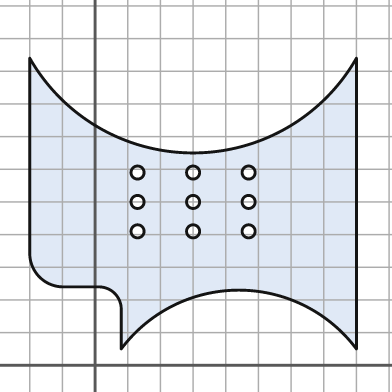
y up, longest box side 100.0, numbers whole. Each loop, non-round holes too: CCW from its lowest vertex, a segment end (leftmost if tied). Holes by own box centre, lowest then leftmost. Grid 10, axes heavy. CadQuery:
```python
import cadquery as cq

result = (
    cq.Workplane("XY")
    .moveTo(8.0, 5.0)
    .threePointArc((44.0, 23.0), (80.0, 5.0))
    .lineTo(80.0, 94.0)
    .threePointArc((30.0, 65.0), (-20.0, 94.0))
    .lineTo(-20.0, 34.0)
    .threePointArc((-17.0, 27.0), (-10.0, 24.0))
    .lineTo(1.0, 24.0)
    .threePointArc((6.0, 22.0), (8.0, 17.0))
    .close()
    .moveTo(13.0, 41.0)
    .circle(2.0)
    .moveTo(30.0, 41.0)
    .circle(2.0)
    .moveTo(47.0, 41.0)
    .circle(2.0)
    .moveTo(13.0, 50.0)
    .circle(2.0)
    .moveTo(30.0, 50.0)
    .circle(2.0)
    .moveTo(47.0, 50.0)
    .circle(2.0)
    .moveTo(13.0, 59.0)
    .circle(2.0)
    .moveTo(30.0, 59.0)
    .circle(2.0)
    .moveTo(47.0, 59.0)
    .circle(2.0)
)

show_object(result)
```